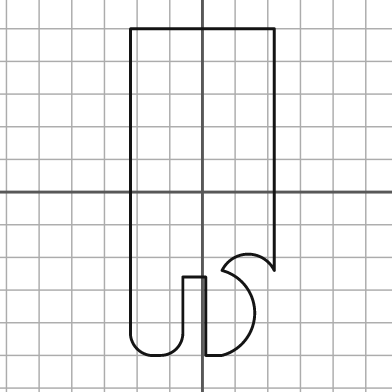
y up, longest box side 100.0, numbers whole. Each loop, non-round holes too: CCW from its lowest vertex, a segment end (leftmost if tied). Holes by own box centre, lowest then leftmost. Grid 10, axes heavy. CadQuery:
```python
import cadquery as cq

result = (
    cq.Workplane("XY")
    .moveTo(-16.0, -50.0)
    .lineTo(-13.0, -50.0)
    .threePointArc((-8.0, -48.0), (-6.0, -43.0))
    .lineTo(-6.0, -26.0)
    .lineTo(1.0, -26.0)
    .lineTo(1.0, -50.0)
    .lineTo(6.0, -50.0)
    .threePointArc((16.0, -37.0), (6.0, -24.0))
    .threePointArc((14.0, -19.0), (22.0, -24.0))
    .lineTo(22.0, 50.0)
    .lineTo(-22.0, 50.0)
    .lineTo(-22.0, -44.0)
    .threePointArc((-20.0, -48.0), (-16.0, -50.0))
    .close()
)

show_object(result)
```